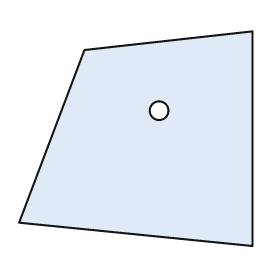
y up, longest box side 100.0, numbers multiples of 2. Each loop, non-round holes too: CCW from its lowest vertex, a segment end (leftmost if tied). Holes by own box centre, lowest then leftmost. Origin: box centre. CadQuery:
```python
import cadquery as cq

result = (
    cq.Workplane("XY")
    .moveTo(50.0, -46.0)
    .lineTo(50.0, 46.0)
    .lineTo(-22.0, 38.0)
    .lineTo(-50.0, -36.0)
    .close()
    .moveTo(10.0, 12.0)
    .circle(4.0)
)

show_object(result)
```